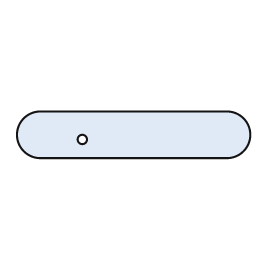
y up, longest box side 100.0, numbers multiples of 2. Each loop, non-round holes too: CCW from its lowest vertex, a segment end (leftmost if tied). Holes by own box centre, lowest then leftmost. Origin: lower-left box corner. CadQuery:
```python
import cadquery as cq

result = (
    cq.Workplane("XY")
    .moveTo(10.0, 0.0)
    .lineTo(90.0, 0.0)
    .threePointArc((100.0, 10.0), (90.0, 20.0))
    .lineTo(10.0, 20.0)
    .threePointArc((0.0, 10.0), (10.0, 0.0))
    .close()
    .moveTo(28.0, 8.0)
    .circle(2.0)
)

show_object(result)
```